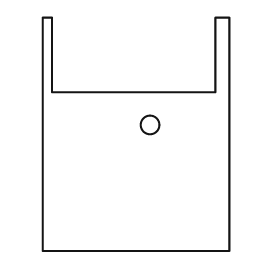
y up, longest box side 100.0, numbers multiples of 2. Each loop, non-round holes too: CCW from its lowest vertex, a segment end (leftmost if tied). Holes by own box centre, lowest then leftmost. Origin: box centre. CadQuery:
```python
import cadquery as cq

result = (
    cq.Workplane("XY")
    .moveTo(-40.0, -50.0)
    .lineTo(40.0, -50.0)
    .lineTo(40.0, 50.0)
    .lineTo(34.0, 50.0)
    .lineTo(34.0, 18.0)
    .lineTo(-36.0, 18.0)
    .lineTo(-36.0, 50.0)
    .lineTo(-40.0, 50.0)
    .close()
    .moveTo(6.0, 4.0)
    .circle(4.0)
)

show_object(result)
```